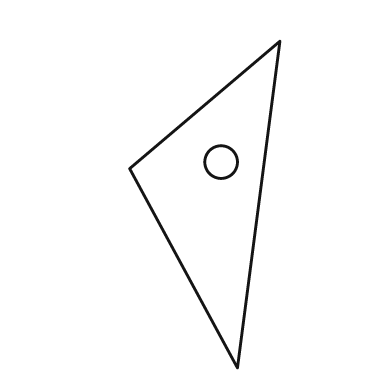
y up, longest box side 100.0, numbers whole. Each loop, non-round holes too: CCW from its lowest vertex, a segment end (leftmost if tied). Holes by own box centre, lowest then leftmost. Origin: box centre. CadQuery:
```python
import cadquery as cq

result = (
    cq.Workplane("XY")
    .moveTo(10.0, -50.0)
    .lineTo(23.0, 50.0)
    .lineTo(-23.0, 11.0)
    .close()
    .moveTo(5.0, 13.0)
    .circle(5.0)
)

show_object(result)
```